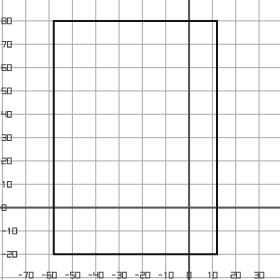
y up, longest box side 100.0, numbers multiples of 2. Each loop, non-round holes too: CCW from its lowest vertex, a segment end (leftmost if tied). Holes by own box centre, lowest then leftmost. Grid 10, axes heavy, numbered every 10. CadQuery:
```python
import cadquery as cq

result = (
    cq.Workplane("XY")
    .moveTo(-58.0, -20.0)
    .lineTo(12.0, -20.0)
    .lineTo(12.0, 80.0)
    .lineTo(-58.0, 80.0)
    .close()
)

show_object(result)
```